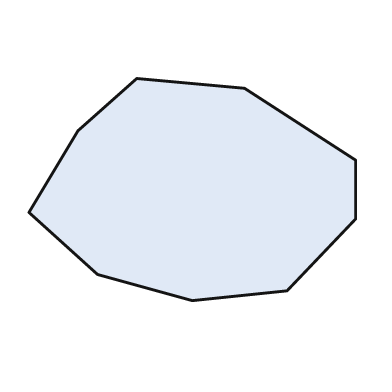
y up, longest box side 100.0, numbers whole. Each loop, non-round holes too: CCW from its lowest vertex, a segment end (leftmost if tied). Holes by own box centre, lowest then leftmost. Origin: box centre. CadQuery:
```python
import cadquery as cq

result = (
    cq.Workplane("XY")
    .moveTo(0.0, -34.0)
    .lineTo(29.0, -31.0)
    .lineTo(50.0, -9.0)
    .lineTo(50.0, 9.0)
    .lineTo(16.0, 31.0)
    .lineTo(-17.0, 34.0)
    .lineTo(-35.0, 18.0)
    .lineTo(-50.0, -7.0)
    .lineTo(-29.0, -26.0)
    .close()
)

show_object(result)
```